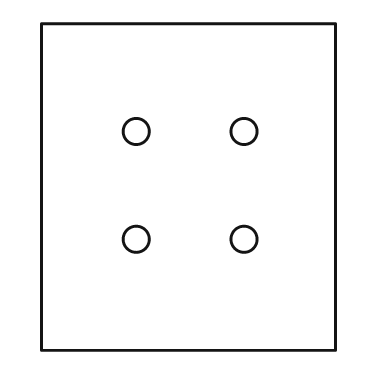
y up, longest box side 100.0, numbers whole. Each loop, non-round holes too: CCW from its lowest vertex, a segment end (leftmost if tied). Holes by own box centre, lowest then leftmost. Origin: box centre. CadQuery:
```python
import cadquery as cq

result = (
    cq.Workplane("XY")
    .moveTo(-45.0, -50.0)
    .lineTo(45.0, -50.0)
    .lineTo(45.0, 50.0)
    .lineTo(-45.0, 50.0)
    .close()
    .moveTo(-16.0, -16.0)
    .circle(4.0)
    .moveTo(17.0, -16.0)
    .circle(4.0)
    .moveTo(-16.0, 17.0)
    .circle(4.0)
    .moveTo(17.0, 17.0)
    .circle(4.0)
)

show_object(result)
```